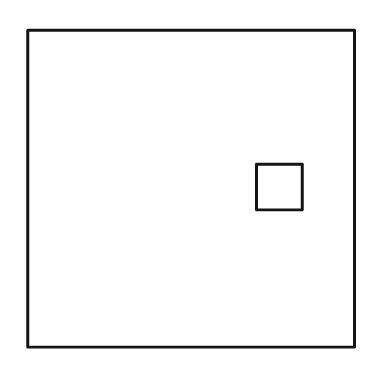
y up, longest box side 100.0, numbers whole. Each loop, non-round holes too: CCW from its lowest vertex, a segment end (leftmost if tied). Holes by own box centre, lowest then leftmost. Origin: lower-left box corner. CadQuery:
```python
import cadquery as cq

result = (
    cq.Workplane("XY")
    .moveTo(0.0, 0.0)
    .lineTo(100.0, 0.0)
    .lineTo(100.0, 97.0)
    .lineTo(0.0, 97.0)
    .close()
    .moveTo(70.0, 42.0)
    .lineTo(84.0, 42.0)
    .lineTo(84.0, 56.0)
    .lineTo(70.0, 56.0)
    .close()
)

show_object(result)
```